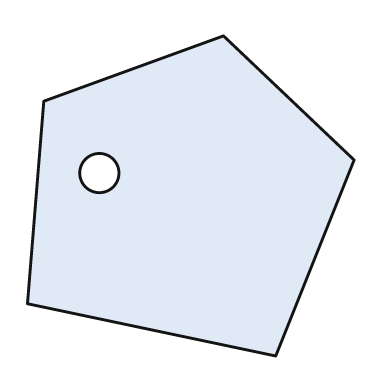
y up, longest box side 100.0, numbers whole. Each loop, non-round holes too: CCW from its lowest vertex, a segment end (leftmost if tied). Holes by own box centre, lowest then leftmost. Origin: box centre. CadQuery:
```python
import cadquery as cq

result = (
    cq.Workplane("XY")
    .moveTo(26.0, -49.0)
    .lineTo(50.0, 11.0)
    .lineTo(10.0, 49.0)
    .lineTo(-45.0, 29.0)
    .lineTo(-50.0, -33.0)
    .close()
    .moveTo(-28.0, 7.0)
    .circle(6.0)
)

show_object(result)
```